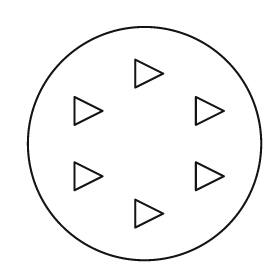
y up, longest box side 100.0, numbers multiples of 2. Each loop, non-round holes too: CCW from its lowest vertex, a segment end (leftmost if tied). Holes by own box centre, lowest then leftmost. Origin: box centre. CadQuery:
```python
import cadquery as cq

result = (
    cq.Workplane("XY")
    .moveTo(0.0, 0.0)
    .circle(50.0)
    .moveTo(-4.0, -36.0)
    .lineTo(8.0, -30.0)
    .lineTo(-4.0, -24.0)
    .close()
    .moveTo(-30.0, -20.0)
    .lineTo(-18.0, -14.0)
    .lineTo(-30.0, -8.0)
    .close()
    .moveTo(22.0, -20.0)
    .lineTo(34.0, -14.0)
    .lineTo(22.0, -8.0)
    .close()
    .moveTo(-30.0, 8.0)
    .lineTo(-18.0, 14.0)
    .lineTo(-30.0, 20.0)
    .close()
    .moveTo(22.0, 8.0)
    .lineTo(34.0, 14.0)
    .lineTo(22.0, 20.0)
    .close()
    .moveTo(-4.0, 24.0)
    .lineTo(8.0, 30.0)
    .lineTo(-4.0, 36.0)
    .close()
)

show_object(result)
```